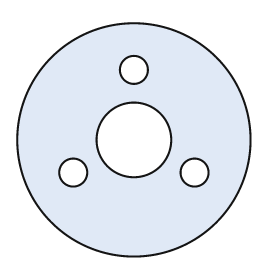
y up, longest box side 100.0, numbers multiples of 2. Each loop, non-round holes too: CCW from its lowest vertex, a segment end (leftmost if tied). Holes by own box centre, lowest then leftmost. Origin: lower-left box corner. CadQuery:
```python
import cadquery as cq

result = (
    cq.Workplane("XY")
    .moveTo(50.0, 50.0)
    .circle(50.0)
    .moveTo(24.0, 36.0)
    .circle(6.0)
    .moveTo(76.0, 36.0)
    .circle(6.0)
    .moveTo(50.0, 50.0)
    .circle(16.0)
    .moveTo(50.0, 80.0)
    .circle(6.0)
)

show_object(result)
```